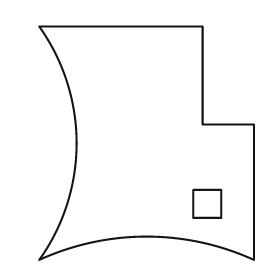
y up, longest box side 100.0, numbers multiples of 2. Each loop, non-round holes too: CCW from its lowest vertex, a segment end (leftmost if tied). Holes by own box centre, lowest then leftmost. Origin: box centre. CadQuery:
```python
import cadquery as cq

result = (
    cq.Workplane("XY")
    .moveTo(-46.0, -50.0)
    .threePointArc((0.0, -40.0), (46.0, -50.0))
    .lineTo(46.0, 8.0)
    .lineTo(24.0, 8.0)
    .lineTo(24.0, 50.0)
    .lineTo(-46.0, 50.0)
    .threePointArc((-30.0, 0.0), (-46.0, -50.0))
    .close()
    .moveTo(20.0, -32.0)
    .lineTo(32.0, -32.0)
    .lineTo(32.0, -20.0)
    .lineTo(20.0, -20.0)
    .close()
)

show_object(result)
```